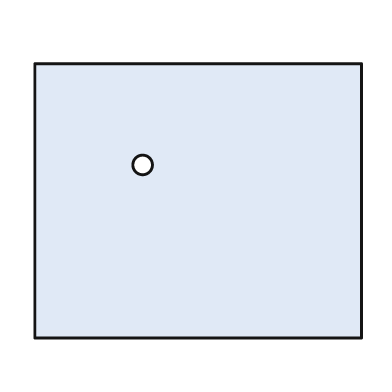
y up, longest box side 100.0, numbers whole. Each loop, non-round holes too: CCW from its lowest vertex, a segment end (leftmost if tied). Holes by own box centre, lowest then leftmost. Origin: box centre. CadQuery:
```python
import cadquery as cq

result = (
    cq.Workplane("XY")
    .moveTo(-50.0, -42.0)
    .lineTo(50.0, -42.0)
    .lineTo(50.0, 42.0)
    .lineTo(-50.0, 42.0)
    .close()
    .moveTo(-17.0, 11.0)
    .circle(3.0)
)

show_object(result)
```